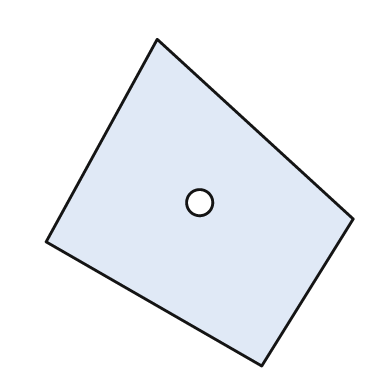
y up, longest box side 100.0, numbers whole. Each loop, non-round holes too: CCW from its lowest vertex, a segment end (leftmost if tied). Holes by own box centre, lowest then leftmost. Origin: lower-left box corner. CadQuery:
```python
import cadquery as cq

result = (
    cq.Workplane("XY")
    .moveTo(66.0, 0.0)
    .lineTo(94.0, 45.0)
    .lineTo(34.0, 100.0)
    .lineTo(0.0, 38.0)
    .close()
    .moveTo(47.0, 50.0)
    .circle(4.0)
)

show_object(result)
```